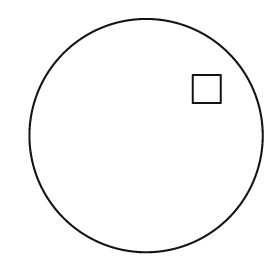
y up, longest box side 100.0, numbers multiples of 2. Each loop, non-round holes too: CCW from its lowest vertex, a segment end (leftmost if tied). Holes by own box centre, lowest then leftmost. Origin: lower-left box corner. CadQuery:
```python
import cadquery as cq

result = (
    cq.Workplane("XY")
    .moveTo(50.0, 50.0)
    .circle(50.0)
    .moveTo(70.0, 64.0)
    .lineTo(82.0, 64.0)
    .lineTo(82.0, 76.0)
    .lineTo(70.0, 76.0)
    .close()
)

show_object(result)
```